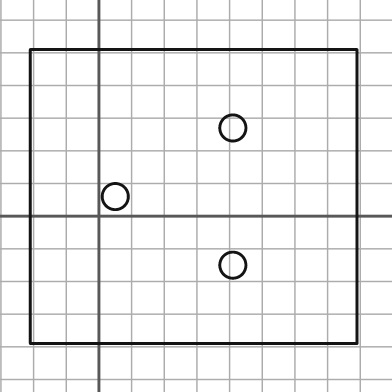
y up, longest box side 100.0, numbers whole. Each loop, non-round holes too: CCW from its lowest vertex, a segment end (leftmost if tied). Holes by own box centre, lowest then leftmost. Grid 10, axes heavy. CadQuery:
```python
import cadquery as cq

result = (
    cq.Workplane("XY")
    .moveTo(-21.0, -39.0)
    .lineTo(79.0, -39.0)
    .lineTo(79.0, 51.0)
    .lineTo(-21.0, 51.0)
    .close()
    .moveTo(41.0, -15.0)
    .circle(4.0)
    .moveTo(5.0, 6.0)
    .circle(4.0)
    .moveTo(41.0, 27.0)
    .circle(4.0)
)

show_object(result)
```